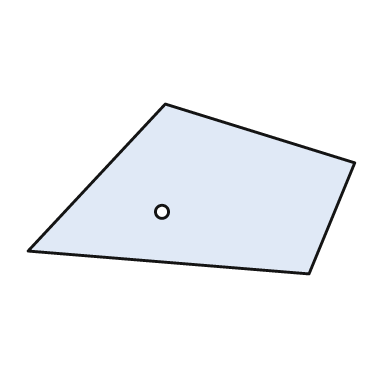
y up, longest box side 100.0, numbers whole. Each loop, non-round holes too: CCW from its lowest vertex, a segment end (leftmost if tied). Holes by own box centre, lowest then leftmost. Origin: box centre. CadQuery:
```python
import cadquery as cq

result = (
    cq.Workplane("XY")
    .moveTo(36.0, -26.0)
    .lineTo(50.0, 8.0)
    .lineTo(-8.0, 26.0)
    .lineTo(-50.0, -19.0)
    .close()
    .moveTo(-9.0, -7.0)
    .circle(2.0)
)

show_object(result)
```